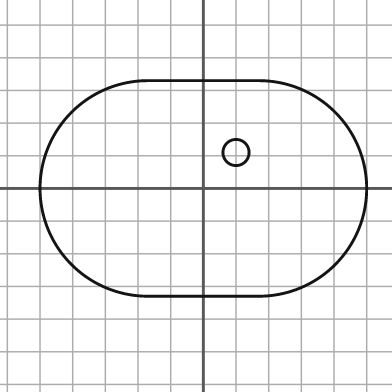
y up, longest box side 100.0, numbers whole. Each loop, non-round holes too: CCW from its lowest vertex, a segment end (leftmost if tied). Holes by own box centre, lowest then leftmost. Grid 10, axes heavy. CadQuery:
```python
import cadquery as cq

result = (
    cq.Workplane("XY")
    .moveTo(-17.0, -33.0)
    .lineTo(17.0, -33.0)
    .threePointArc((50.0, 0.0), (17.0, 33.0))
    .lineTo(-17.0, 33.0)
    .threePointArc((-50.0, 0.0), (-17.0, -33.0))
    .close()
    .moveTo(10.0, 11.0)
    .circle(4.0)
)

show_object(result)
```